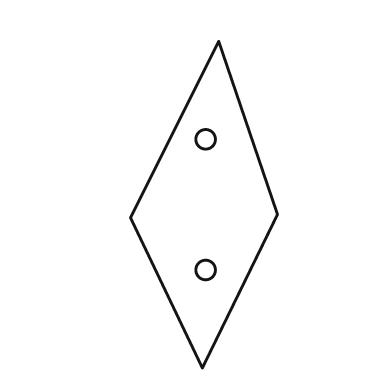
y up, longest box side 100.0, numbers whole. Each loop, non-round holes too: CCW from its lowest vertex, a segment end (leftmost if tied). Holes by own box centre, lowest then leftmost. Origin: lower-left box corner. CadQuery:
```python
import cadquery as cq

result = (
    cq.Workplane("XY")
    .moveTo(22.0, 0.0)
    .lineTo(45.0, 47.0)
    .lineTo(27.0, 100.0)
    .lineTo(0.0, 46.0)
    .close()
    .moveTo(23.0, 30.0)
    .circle(3.0)
    .moveTo(23.0, 70.0)
    .circle(3.0)
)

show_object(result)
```